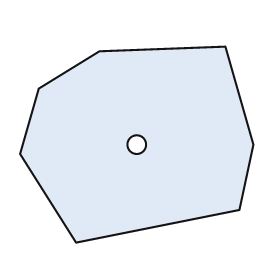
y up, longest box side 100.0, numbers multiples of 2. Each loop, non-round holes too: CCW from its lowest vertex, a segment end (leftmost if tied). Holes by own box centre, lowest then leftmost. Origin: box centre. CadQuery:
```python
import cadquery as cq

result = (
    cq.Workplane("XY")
    .moveTo(-26.0, -42.0)
    .lineTo(44.0, -28.0)
    .lineTo(50.0, 0.0)
    .lineTo(38.0, 42.0)
    .lineTo(-16.0, 40.0)
    .lineTo(-42.0, 24.0)
    .lineTo(-50.0, -4.0)
    .close()
    .moveTo(0.0, 0.0)
    .circle(4.0)
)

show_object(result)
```